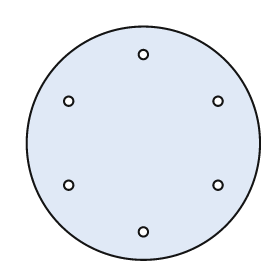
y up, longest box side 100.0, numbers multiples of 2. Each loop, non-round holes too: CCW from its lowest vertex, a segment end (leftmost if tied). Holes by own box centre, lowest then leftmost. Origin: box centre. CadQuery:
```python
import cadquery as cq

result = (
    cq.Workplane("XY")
    .moveTo(0.0, 0.0)
    .circle(50.0)
    .moveTo(0.0, -38.0)
    .circle(2.0)
    .moveTo(-32.0, -18.0)
    .circle(2.0)
    .moveTo(32.0, -18.0)
    .circle(2.0)
    .moveTo(-32.0, 18.0)
    .circle(2.0)
    .moveTo(32.0, 18.0)
    .circle(2.0)
    .moveTo(0.0, 38.0)
    .circle(2.0)
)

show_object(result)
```